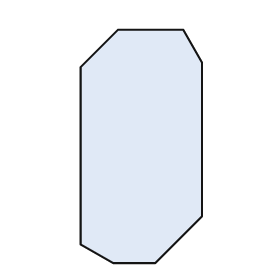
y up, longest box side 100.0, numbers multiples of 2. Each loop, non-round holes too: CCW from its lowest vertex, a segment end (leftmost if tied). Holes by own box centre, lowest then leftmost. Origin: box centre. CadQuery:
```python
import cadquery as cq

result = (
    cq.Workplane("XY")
    .moveTo(-12.0, -50.0)
    .lineTo(6.0, -50.0)
    .lineTo(26.0, -30.0)
    .lineTo(26.0, 36.0)
    .lineTo(18.0, 50.0)
    .lineTo(-10.0, 50.0)
    .lineTo(-26.0, 34.0)
    .lineTo(-26.0, -42.0)
    .close()
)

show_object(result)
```